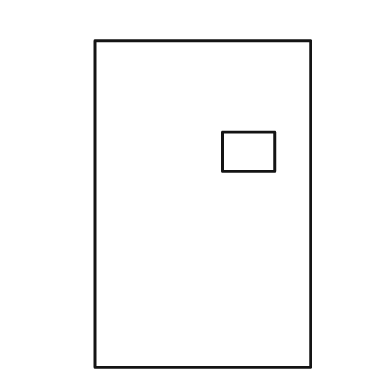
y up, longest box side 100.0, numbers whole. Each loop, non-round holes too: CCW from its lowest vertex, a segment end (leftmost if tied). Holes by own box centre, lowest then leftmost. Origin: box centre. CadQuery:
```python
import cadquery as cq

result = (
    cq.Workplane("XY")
    .moveTo(-33.0, -50.0)
    .lineTo(33.0, -50.0)
    .lineTo(33.0, 50.0)
    .lineTo(-33.0, 50.0)
    .close()
    .moveTo(6.0, 10.0)
    .lineTo(22.0, 10.0)
    .lineTo(22.0, 22.0)
    .lineTo(6.0, 22.0)
    .close()
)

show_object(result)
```